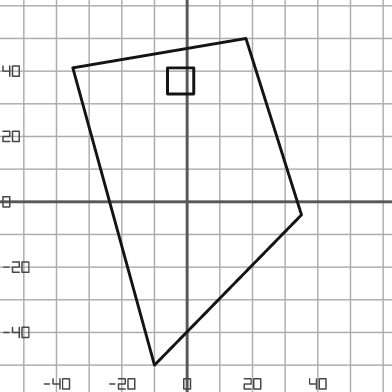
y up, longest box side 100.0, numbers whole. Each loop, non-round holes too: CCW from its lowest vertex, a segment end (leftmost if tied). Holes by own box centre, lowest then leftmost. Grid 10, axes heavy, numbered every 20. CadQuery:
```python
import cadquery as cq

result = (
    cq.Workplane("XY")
    .moveTo(-10.0, -50.0)
    .lineTo(35.0, -4.0)
    .lineTo(18.0, 50.0)
    .lineTo(-35.0, 41.0)
    .close()
    .moveTo(-6.0, 33.0)
    .lineTo(2.0, 33.0)
    .lineTo(2.0, 41.0)
    .lineTo(-6.0, 41.0)
    .close()
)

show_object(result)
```